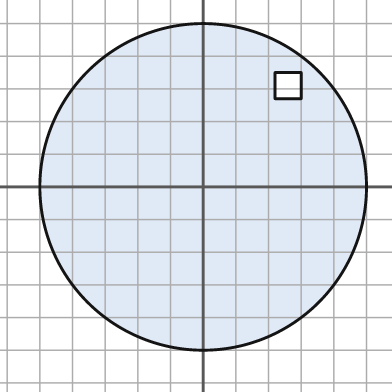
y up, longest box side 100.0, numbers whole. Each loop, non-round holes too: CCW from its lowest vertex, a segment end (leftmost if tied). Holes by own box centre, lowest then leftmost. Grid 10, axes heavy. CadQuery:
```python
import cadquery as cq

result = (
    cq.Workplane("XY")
    .moveTo(0.0, 0.0)
    .circle(50.0)
    .moveTo(22.0, 27.0)
    .lineTo(30.0, 27.0)
    .lineTo(30.0, 35.0)
    .lineTo(22.0, 35.0)
    .close()
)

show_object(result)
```